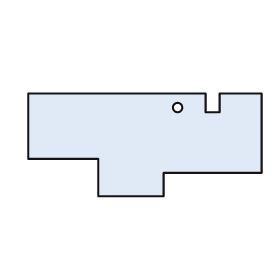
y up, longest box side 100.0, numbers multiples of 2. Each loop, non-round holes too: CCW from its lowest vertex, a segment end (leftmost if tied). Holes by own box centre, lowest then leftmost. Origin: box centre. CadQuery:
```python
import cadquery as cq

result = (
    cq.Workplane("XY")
    .moveTo(-20.0, -22.0)
    .lineTo(8.0, -22.0)
    .lineTo(8.0, -12.0)
    .lineTo(50.0, -12.0)
    .lineTo(50.0, 22.0)
    .lineTo(32.0, 22.0)
    .lineTo(32.0, 14.0)
    .lineTo(26.0, 14.0)
    .lineTo(26.0, 22.0)
    .lineTo(-50.0, 22.0)
    .lineTo(-50.0, -6.0)
    .lineTo(-20.0, -6.0)
    .close()
    .moveTo(14.0, 16.0)
    .circle(2.0)
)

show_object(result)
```